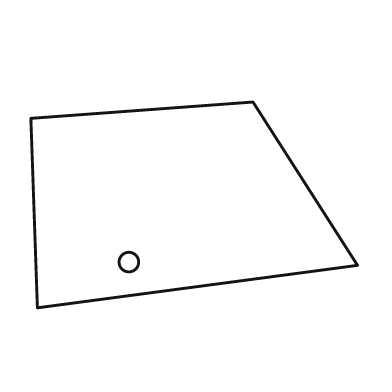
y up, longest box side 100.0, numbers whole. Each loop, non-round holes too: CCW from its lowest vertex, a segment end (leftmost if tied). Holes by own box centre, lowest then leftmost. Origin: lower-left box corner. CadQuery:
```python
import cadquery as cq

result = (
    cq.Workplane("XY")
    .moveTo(2.0, 0.0)
    .lineTo(100.0, 13.0)
    .lineTo(68.0, 63.0)
    .lineTo(0.0, 58.0)
    .close()
    .moveTo(30.0, 14.0)
    .circle(3.0)
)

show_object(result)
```